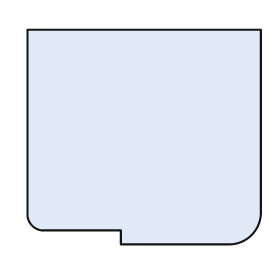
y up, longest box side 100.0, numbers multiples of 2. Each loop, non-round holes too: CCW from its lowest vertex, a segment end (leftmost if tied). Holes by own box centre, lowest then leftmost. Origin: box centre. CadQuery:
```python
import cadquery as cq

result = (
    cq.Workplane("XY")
    .moveTo(-10.0, -46.0)
    .lineTo(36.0, -46.0)
    .threePointArc((46.0, -42.0), (50.0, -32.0))
    .lineTo(50.0, 46.0)
    .lineTo(-50.0, 46.0)
    .lineTo(-50.0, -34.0)
    .threePointArc((-48.0, -38.0), (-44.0, -40.0))
    .lineTo(-10.0, -40.0)
    .close()
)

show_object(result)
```